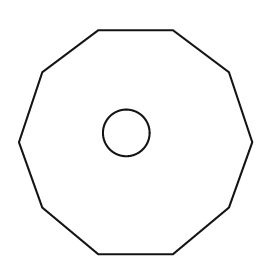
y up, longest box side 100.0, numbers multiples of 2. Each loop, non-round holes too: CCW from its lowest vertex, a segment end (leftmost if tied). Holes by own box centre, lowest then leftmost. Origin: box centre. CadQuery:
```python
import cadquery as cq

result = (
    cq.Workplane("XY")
    .moveTo(-16.0, -48.0)
    .lineTo(16.0, -48.0)
    .lineTo(40.0, -28.0)
    .lineTo(50.0, 0.0)
    .lineTo(40.0, 30.0)
    .lineTo(16.0, 48.0)
    .lineTo(-16.0, 48.0)
    .lineTo(-40.0, 30.0)
    .lineTo(-50.0, 0.0)
    .lineTo(-40.0, -28.0)
    .close()
    .moveTo(-4.0, 4.0)
    .circle(10.0)
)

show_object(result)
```